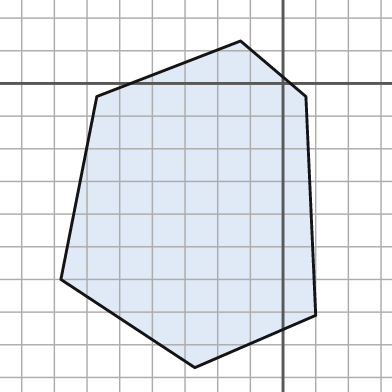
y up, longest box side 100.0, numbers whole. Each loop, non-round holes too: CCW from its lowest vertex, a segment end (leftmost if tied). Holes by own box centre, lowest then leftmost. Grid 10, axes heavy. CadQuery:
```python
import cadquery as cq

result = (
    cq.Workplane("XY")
    .moveTo(-27.0, -87.0)
    .lineTo(10.0, -71.0)
    .lineTo(7.0, -4.0)
    .lineTo(-13.0, 13.0)
    .lineTo(-57.0, -4.0)
    .lineTo(-68.0, -60.0)
    .close()
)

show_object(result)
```